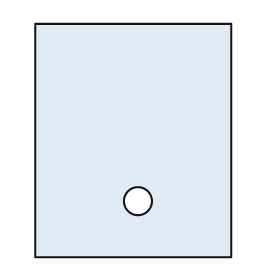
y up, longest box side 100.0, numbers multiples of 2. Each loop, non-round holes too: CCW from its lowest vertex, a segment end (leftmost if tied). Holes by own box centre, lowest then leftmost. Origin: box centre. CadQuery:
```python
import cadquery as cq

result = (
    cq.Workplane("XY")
    .moveTo(-42.0, -50.0)
    .lineTo(42.0, -50.0)
    .lineTo(42.0, 50.0)
    .lineTo(-42.0, 50.0)
    .close()
    .moveTo(2.0, -26.0)
    .circle(6.0)
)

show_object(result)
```